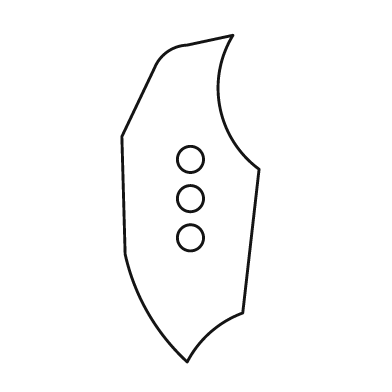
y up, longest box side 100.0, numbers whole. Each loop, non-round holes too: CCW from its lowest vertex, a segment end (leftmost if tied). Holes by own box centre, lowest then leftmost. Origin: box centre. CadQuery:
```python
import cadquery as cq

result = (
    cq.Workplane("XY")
    .moveTo(-1.0, -50.0)
    .threePointArc((6.0, -41.0), (16.0, -35.0))
    .lineTo(21.0, 9.0)
    .threePointArc((9.0, 28.0), (13.0, 50.0))
    .lineTo(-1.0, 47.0)
    .threePointArc((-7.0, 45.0), (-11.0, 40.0))
    .lineTo(-21.0, 19.0)
    .lineTo(-20.0, -17.0)
    .threePointArc((-13.0, -35.0), (-1.0, -50.0))
    .close()
    .moveTo(0.0, -12.0)
    .circle(4.0)
    .moveTo(0.0, 0.0)
    .circle(4.0)
    .moveTo(0.0, 12.0)
    .circle(4.0)
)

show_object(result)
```